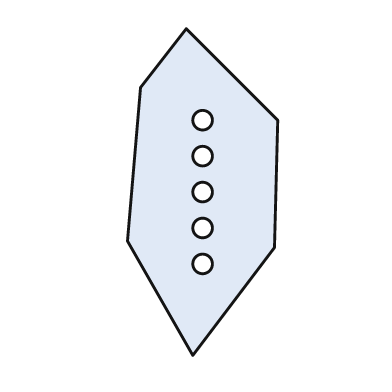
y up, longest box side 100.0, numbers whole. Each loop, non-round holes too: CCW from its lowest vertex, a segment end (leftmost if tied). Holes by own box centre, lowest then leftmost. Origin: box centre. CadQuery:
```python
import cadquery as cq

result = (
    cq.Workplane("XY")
    .moveTo(-3.0, -50.0)
    .lineTo(22.0, -17.0)
    .lineTo(23.0, 22.0)
    .lineTo(-5.0, 50.0)
    .lineTo(-19.0, 32.0)
    .lineTo(-23.0, -15.0)
    .close()
    .moveTo(0.0, -22.0)
    .circle(3.0)
    .moveTo(0.0, -11.0)
    .circle(3.0)
    .moveTo(0.0, 0.0)
    .circle(3.0)
    .moveTo(0.0, 11.0)
    .circle(3.0)
    .moveTo(0.0, 22.0)
    .circle(3.0)
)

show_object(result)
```